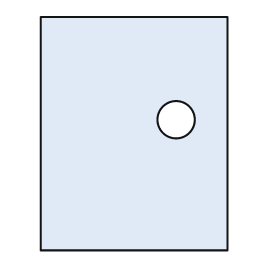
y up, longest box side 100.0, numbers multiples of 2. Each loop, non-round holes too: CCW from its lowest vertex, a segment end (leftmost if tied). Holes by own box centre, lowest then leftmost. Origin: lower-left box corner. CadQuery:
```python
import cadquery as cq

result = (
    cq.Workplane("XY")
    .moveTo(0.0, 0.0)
    .lineTo(80.0, 0.0)
    .lineTo(80.0, 100.0)
    .lineTo(0.0, 100.0)
    .close()
    .moveTo(58.0, 56.0)
    .circle(8.0)
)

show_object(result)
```